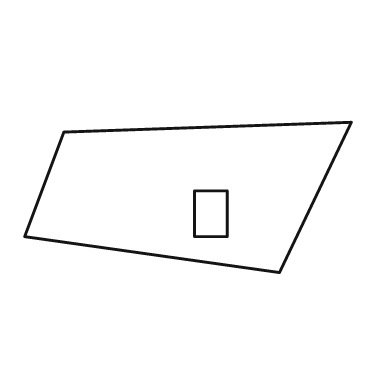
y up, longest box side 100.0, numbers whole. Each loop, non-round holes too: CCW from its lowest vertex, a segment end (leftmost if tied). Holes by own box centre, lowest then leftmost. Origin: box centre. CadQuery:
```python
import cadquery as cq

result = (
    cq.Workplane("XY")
    .moveTo(28.0, -23.0)
    .lineTo(50.0, 23.0)
    .lineTo(-38.0, 20.0)
    .lineTo(-50.0, -12.0)
    .close()
    .moveTo(2.0, -12.0)
    .lineTo(12.0, -12.0)
    .lineTo(12.0, 2.0)
    .lineTo(2.0, 2.0)
    .close()
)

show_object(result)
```